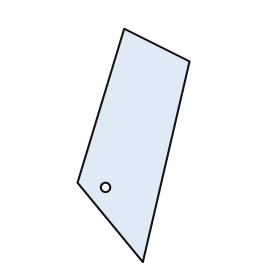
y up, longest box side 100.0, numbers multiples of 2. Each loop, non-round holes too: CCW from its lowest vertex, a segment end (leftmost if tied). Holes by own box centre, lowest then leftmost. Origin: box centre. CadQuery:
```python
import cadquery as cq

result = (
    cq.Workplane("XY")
    .moveTo(4.0, -50.0)
    .lineTo(24.0, 36.0)
    .lineTo(-4.0, 50.0)
    .lineTo(-24.0, -16.0)
    .close()
    .moveTo(-12.0, -18.0)
    .circle(2.0)
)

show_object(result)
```